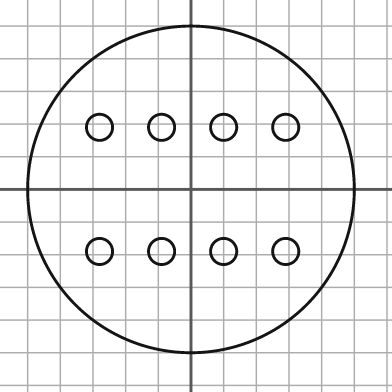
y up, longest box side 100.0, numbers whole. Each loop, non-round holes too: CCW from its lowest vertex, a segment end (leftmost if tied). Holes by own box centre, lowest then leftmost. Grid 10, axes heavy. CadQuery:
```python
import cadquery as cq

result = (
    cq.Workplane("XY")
    .moveTo(0.0, 0.0)
    .circle(50.0)
    .moveTo(-28.0, -19.0)
    .circle(4.0)
    .moveTo(-9.0, -19.0)
    .circle(4.0)
    .moveTo(10.0, -19.0)
    .circle(4.0)
    .moveTo(29.0, -19.0)
    .circle(4.0)
    .moveTo(-28.0, 19.0)
    .circle(4.0)
    .moveTo(-9.0, 19.0)
    .circle(4.0)
    .moveTo(10.0, 19.0)
    .circle(4.0)
    .moveTo(29.0, 19.0)
    .circle(4.0)
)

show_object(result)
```